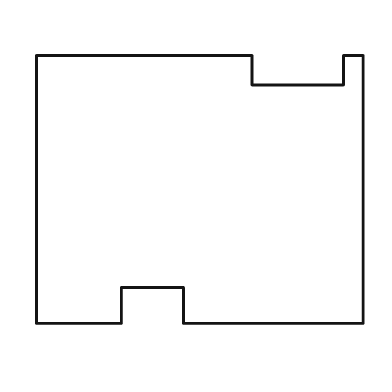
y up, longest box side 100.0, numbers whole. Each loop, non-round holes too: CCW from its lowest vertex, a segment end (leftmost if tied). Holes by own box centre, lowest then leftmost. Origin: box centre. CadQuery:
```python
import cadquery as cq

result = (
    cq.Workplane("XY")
    .moveTo(-50.0, -41.0)
    .lineTo(-24.0, -41.0)
    .lineTo(-24.0, -30.0)
    .lineTo(-5.0, -30.0)
    .lineTo(-5.0, -41.0)
    .lineTo(50.0, -41.0)
    .lineTo(50.0, 41.0)
    .lineTo(44.0, 41.0)
    .lineTo(44.0, 32.0)
    .lineTo(16.0, 32.0)
    .lineTo(16.0, 41.0)
    .lineTo(-50.0, 41.0)
    .close()
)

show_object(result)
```